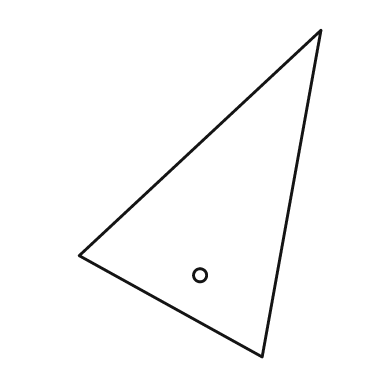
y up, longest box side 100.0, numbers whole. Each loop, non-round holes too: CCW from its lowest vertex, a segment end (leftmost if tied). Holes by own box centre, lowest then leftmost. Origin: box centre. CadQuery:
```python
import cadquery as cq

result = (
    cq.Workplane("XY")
    .moveTo(19.0, -50.0)
    .lineTo(37.0, 50.0)
    .lineTo(-37.0, -19.0)
    .close()
    .moveTo(0.0, -25.0)
    .circle(2.0)
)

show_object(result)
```